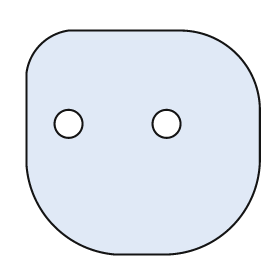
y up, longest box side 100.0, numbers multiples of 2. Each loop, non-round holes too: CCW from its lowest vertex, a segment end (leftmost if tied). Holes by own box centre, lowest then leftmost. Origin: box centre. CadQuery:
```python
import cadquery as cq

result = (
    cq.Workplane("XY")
    .moveTo(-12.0, -48.0)
    .lineTo(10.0, -48.0)
    .threePointArc((38.0, -36.0), (50.0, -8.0))
    .lineTo(50.0, 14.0)
    .threePointArc((40.0, 38.0), (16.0, 48.0))
    .lineTo(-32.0, 48.0)
    .threePointArc((-44.0, 42.0), (-50.0, 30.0))
    .lineTo(-50.0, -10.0)
    .threePointArc((-38.0, -36.0), (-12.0, -48.0))
    .close()
    .moveTo(-32.0, 8.0)
    .circle(6.0)
    .moveTo(10.0, 8.0)
    .circle(6.0)
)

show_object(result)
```